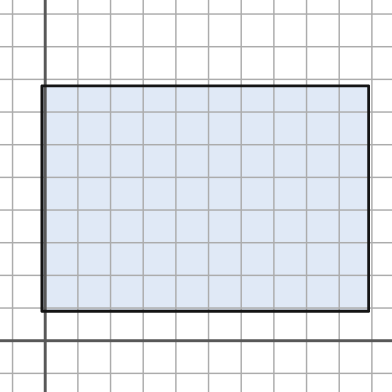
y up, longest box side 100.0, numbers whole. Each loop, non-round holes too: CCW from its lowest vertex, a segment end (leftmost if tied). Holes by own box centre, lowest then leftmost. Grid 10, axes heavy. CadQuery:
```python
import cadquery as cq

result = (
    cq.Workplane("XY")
    .moveTo(-1.0, 9.0)
    .lineTo(99.0, 9.0)
    .lineTo(99.0, 78.0)
    .lineTo(-1.0, 78.0)
    .close()
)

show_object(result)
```